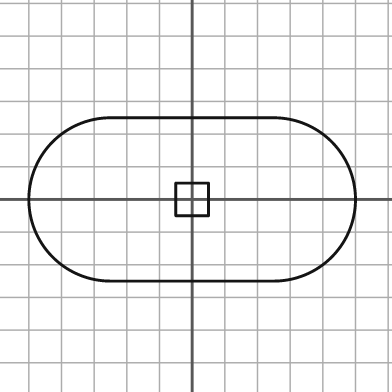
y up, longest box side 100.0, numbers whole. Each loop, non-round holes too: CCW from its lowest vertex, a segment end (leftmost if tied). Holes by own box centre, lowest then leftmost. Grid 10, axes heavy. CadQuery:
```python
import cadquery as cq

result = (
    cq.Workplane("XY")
    .moveTo(-25.0, -25.0)
    .lineTo(25.0, -25.0)
    .threePointArc((50.0, 0.0), (25.0, 25.0))
    .lineTo(-25.0, 25.0)
    .threePointArc((-50.0, 0.0), (-25.0, -25.0))
    .close()
    .moveTo(-5.0, -5.0)
    .lineTo(5.0, -5.0)
    .lineTo(5.0, 5.0)
    .lineTo(-5.0, 5.0)
    .close()
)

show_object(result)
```